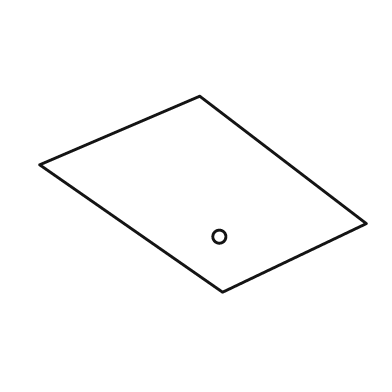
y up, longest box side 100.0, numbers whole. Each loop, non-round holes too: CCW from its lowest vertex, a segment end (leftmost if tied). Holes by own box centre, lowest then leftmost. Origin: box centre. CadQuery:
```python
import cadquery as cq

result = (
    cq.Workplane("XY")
    .moveTo(6.0, -30.0)
    .lineTo(50.0, -9.0)
    .lineTo(-1.0, 30.0)
    .lineTo(-50.0, 9.0)
    .close()
    .moveTo(5.0, -13.0)
    .circle(2.0)
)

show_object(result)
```